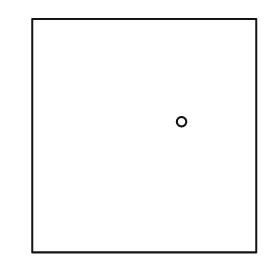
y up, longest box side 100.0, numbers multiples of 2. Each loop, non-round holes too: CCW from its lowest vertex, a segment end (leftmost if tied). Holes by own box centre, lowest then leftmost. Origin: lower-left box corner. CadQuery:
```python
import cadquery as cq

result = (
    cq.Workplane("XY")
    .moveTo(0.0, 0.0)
    .lineTo(96.0, 0.0)
    .lineTo(96.0, 100.0)
    .lineTo(0.0, 100.0)
    .close()
    .moveTo(64.0, 56.0)
    .circle(2.0)
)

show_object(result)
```